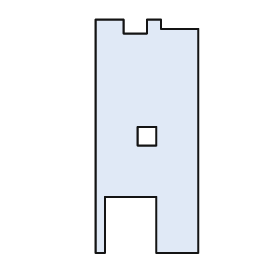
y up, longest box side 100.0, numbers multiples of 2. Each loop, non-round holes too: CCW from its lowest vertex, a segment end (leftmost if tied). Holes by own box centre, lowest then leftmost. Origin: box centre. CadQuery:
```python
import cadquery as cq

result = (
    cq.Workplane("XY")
    .moveTo(-22.0, -50.0)
    .lineTo(-18.0, -50.0)
    .lineTo(-18.0, -26.0)
    .lineTo(4.0, -26.0)
    .lineTo(4.0, -50.0)
    .lineTo(22.0, -50.0)
    .lineTo(22.0, 46.0)
    .lineTo(6.0, 46.0)
    .lineTo(6.0, 50.0)
    .lineTo(0.0, 50.0)
    .lineTo(0.0, 44.0)
    .lineTo(-10.0, 44.0)
    .lineTo(-10.0, 50.0)
    .lineTo(-22.0, 50.0)
    .close()
    .moveTo(-4.0, -4.0)
    .lineTo(4.0, -4.0)
    .lineTo(4.0, 4.0)
    .lineTo(-4.0, 4.0)
    .close()
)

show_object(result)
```